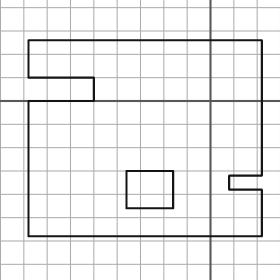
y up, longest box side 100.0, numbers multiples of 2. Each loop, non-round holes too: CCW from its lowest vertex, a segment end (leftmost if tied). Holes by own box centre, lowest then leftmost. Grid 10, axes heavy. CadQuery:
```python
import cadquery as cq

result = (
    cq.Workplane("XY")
    .moveTo(-78.0, -58.0)
    .lineTo(22.0, -58.0)
    .lineTo(22.0, -38.0)
    .lineTo(8.0, -38.0)
    .lineTo(8.0, -32.0)
    .lineTo(22.0, -32.0)
    .lineTo(22.0, 26.0)
    .lineTo(-78.0, 26.0)
    .lineTo(-78.0, 10.0)
    .lineTo(-50.0, 10.0)
    .lineTo(-50.0, 0.0)
    .lineTo(-78.0, 0.0)
    .close()
    .moveTo(-36.0, -46.0)
    .lineTo(-16.0, -46.0)
    .lineTo(-16.0, -30.0)
    .lineTo(-36.0, -30.0)
    .close()
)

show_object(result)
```